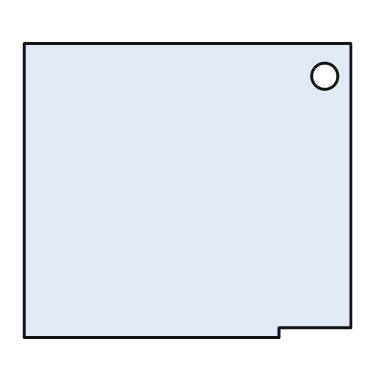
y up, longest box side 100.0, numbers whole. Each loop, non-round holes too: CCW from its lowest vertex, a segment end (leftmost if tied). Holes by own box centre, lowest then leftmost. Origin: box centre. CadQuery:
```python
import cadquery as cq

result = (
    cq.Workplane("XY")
    .moveTo(-50.0, -45.0)
    .lineTo(28.0, -45.0)
    .lineTo(28.0, -42.0)
    .lineTo(50.0, -42.0)
    .lineTo(50.0, 45.0)
    .lineTo(-50.0, 45.0)
    .close()
    .moveTo(42.0, 35.0)
    .circle(4.0)
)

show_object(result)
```